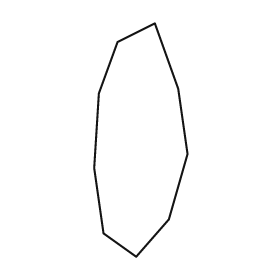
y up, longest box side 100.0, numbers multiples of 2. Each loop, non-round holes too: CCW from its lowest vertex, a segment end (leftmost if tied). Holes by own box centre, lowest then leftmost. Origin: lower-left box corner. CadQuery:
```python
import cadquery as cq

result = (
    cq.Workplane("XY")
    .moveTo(18.0, 0.0)
    .lineTo(32.0, 16.0)
    .lineTo(40.0, 44.0)
    .lineTo(36.0, 72.0)
    .lineTo(26.0, 100.0)
    .lineTo(10.0, 92.0)
    .lineTo(2.0, 70.0)
    .lineTo(0.0, 38.0)
    .lineTo(4.0, 10.0)
    .close()
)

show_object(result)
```